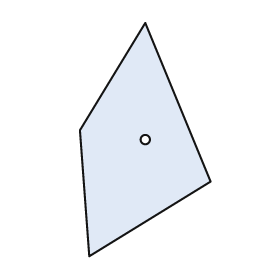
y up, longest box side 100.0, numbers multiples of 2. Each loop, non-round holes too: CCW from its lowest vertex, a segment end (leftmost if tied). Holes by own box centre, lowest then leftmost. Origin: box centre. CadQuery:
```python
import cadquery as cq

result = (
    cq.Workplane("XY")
    .moveTo(-24.0, -50.0)
    .lineTo(28.0, -18.0)
    .lineTo(0.0, 50.0)
    .lineTo(-28.0, 4.0)
    .close()
    .moveTo(0.0, 0.0)
    .circle(2.0)
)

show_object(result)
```